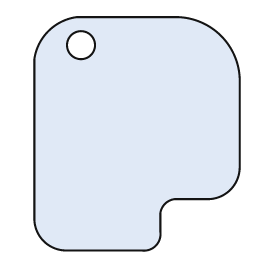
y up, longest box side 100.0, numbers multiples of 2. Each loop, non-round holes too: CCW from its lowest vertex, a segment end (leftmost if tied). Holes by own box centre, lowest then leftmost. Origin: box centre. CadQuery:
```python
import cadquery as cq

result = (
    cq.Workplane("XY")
    .moveTo(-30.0, -50.0)
    .lineTo(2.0, -50.0)
    .threePointArc((8.0, -48.0), (10.0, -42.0))
    .lineTo(10.0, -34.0)
    .threePointArc((12.0, -30.0), (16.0, -28.0))
    .lineTo(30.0, -28.0)
    .threePointArc((40.0, -24.0), (44.0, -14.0))
    .lineTo(44.0, 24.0)
    .threePointArc((36.0, 42.0), (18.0, 50.0))
    .lineTo(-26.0, 50.0)
    .threePointArc((-38.0, 44.0), (-44.0, 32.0))
    .lineTo(-44.0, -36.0)
    .threePointArc((-40.0, -46.0), (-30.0, -50.0))
    .close()
    .moveTo(-24.0, 38.0)
    .circle(6.0)
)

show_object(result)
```